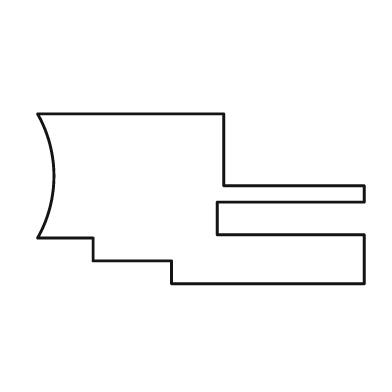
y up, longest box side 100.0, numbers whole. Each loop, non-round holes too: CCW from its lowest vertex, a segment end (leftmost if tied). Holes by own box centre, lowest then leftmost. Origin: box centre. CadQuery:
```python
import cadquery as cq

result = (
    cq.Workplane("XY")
    .moveTo(-9.0, -26.0)
    .lineTo(50.0, -26.0)
    .lineTo(50.0, -11.0)
    .lineTo(5.0, -11.0)
    .lineTo(5.0, -1.0)
    .lineTo(50.0, -1.0)
    .lineTo(50.0, 4.0)
    .lineTo(7.0, 4.0)
    .lineTo(7.0, 26.0)
    .lineTo(-50.0, 26.0)
    .threePointArc((-45.0, 7.0), (-50.0, -12.0))
    .lineTo(-33.0, -12.0)
    .lineTo(-33.0, -19.0)
    .lineTo(-9.0, -19.0)
    .close()
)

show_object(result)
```